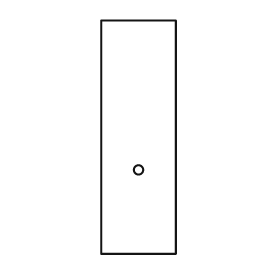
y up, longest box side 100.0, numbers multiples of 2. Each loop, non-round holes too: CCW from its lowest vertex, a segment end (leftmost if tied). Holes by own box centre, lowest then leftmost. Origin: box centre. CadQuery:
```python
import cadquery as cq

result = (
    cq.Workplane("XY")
    .moveTo(-16.0, -50.0)
    .lineTo(16.0, -50.0)
    .lineTo(16.0, 50.0)
    .lineTo(-16.0, 50.0)
    .close()
    .moveTo(0.0, -14.0)
    .circle(2.0)
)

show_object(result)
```